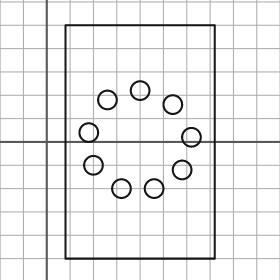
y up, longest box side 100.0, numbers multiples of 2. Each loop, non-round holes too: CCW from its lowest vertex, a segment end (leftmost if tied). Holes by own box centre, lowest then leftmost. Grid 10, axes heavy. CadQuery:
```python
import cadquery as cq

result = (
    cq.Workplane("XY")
    .moveTo(8.0, -50.0)
    .lineTo(72.0, -50.0)
    .lineTo(72.0, 50.0)
    .lineTo(8.0, 50.0)
    .close()
    .moveTo(32.0, -20.0)
    .circle(4.0)
    .moveTo(46.0, -20.0)
    .circle(4.0)
    .moveTo(58.0, -12.0)
    .circle(4.0)
    .moveTo(20.0, -10.0)
    .circle(4.0)
    .moveTo(62.0, 2.0)
    .circle(4.0)
    .moveTo(18.0, 4.0)
    .circle(4.0)
    .moveTo(54.0, 16.0)
    .circle(4.0)
    .moveTo(26.0, 18.0)
    .circle(4.0)
    .moveTo(40.0, 22.0)
    .circle(4.0)
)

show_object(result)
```